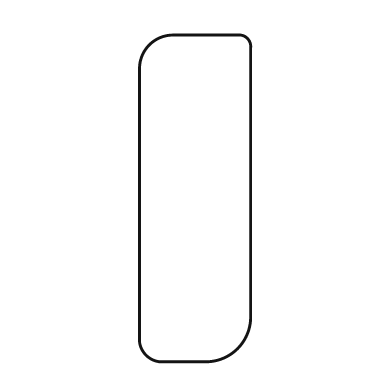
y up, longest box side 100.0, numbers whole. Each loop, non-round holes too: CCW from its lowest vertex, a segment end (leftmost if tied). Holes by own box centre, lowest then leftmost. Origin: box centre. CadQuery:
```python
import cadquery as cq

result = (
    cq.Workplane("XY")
    .moveTo(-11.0, -50.0)
    .lineTo(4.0, -50.0)
    .threePointArc((13.0, -46.0), (17.0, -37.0))
    .lineTo(17.0, 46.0)
    .threePointArc((16.0, 49.0), (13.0, 50.0))
    .lineTo(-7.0, 50.0)
    .threePointArc((-14.0, 47.0), (-17.0, 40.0))
    .lineTo(-17.0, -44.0)
    .threePointArc((-15.0, -48.0), (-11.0, -50.0))
    .close()
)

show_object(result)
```